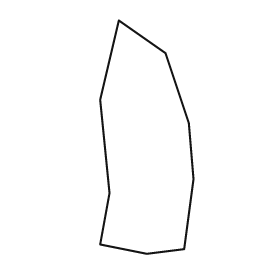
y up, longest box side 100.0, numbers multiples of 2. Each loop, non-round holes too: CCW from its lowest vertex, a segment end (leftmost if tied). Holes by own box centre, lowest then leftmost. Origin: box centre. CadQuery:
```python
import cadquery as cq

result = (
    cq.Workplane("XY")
    .moveTo(0.0, -50.0)
    .lineTo(16.0, -48.0)
    .lineTo(20.0, -18.0)
    .lineTo(18.0, 6.0)
    .lineTo(8.0, 36.0)
    .lineTo(-12.0, 50.0)
    .lineTo(-20.0, 16.0)
    .lineTo(-16.0, -24.0)
    .lineTo(-20.0, -46.0)
    .close()
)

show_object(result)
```